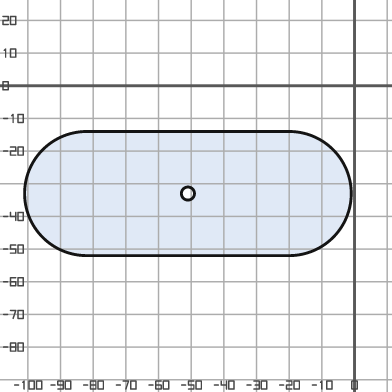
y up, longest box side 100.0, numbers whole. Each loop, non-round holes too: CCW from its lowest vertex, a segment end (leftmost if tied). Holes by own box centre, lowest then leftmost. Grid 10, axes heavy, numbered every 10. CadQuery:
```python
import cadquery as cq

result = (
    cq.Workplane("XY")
    .moveTo(-82.0, -52.0)
    .lineTo(-20.0, -52.0)
    .threePointArc((-1.0, -33.0), (-20.0, -14.0))
    .lineTo(-82.0, -14.0)
    .threePointArc((-101.0, -33.0), (-82.0, -52.0))
    .close()
    .moveTo(-51.0, -33.0)
    .circle(2.0)
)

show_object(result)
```